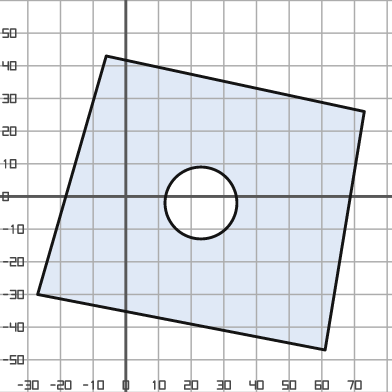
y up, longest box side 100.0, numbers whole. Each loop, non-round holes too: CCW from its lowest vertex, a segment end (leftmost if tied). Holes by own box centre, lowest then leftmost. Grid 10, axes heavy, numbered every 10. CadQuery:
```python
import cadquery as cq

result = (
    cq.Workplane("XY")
    .moveTo(61.0, -47.0)
    .lineTo(73.0, 26.0)
    .lineTo(-6.0, 43.0)
    .lineTo(-27.0, -30.0)
    .close()
    .moveTo(23.0, -2.0)
    .circle(11.0)
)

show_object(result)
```